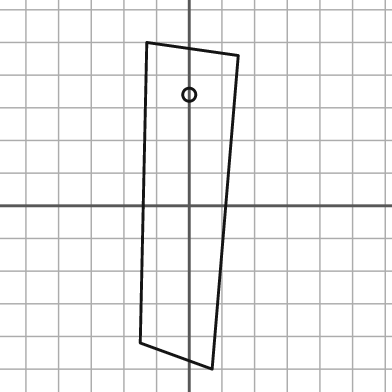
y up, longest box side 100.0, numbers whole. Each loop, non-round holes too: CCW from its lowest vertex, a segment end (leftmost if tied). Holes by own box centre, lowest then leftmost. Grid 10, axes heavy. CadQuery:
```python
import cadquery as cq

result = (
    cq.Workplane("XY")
    .moveTo(7.0, -50.0)
    .lineTo(15.0, 46.0)
    .lineTo(-13.0, 50.0)
    .lineTo(-15.0, -42.0)
    .close()
    .moveTo(0.0, 34.0)
    .circle(2.0)
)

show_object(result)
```